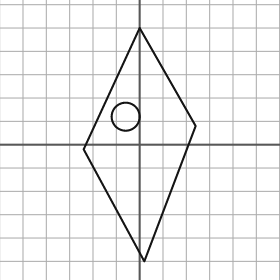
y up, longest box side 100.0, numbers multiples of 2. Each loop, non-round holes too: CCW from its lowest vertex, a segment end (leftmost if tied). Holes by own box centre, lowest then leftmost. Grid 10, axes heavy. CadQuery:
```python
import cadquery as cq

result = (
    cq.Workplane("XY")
    .moveTo(2.0, -50.0)
    .lineTo(24.0, 8.0)
    .lineTo(0.0, 50.0)
    .lineTo(-24.0, -2.0)
    .close()
    .moveTo(-6.0, 12.0)
    .circle(6.0)
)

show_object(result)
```